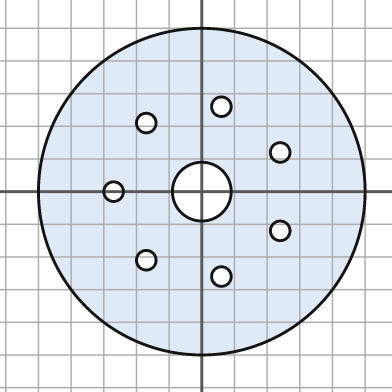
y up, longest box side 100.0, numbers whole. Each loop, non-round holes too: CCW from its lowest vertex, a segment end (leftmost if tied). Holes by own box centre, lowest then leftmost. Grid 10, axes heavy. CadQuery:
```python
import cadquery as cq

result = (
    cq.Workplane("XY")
    .moveTo(0.0, 0.0)
    .circle(50.0)
    .moveTo(6.0, -26.0)
    .circle(3.0)
    .moveTo(-17.0, -21.0)
    .circle(3.0)
    .moveTo(24.0, -12.0)
    .circle(3.0)
    .moveTo(-27.0, 0.0)
    .circle(3.0)
    .moveTo(0.0, 0.0)
    .circle(9.0)
    .moveTo(24.0, 12.0)
    .circle(3.0)
    .moveTo(-17.0, 21.0)
    .circle(3.0)
    .moveTo(6.0, 26.0)
    .circle(3.0)
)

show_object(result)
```